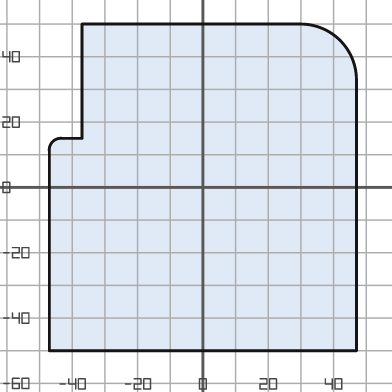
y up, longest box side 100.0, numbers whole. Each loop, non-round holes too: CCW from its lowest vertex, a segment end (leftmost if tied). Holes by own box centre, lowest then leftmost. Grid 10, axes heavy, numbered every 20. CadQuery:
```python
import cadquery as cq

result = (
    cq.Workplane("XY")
    .moveTo(-47.0, -50.0)
    .lineTo(47.0, -50.0)
    .lineTo(47.0, 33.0)
    .threePointArc((42.0, 45.0), (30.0, 50.0))
    .lineTo(-37.0, 50.0)
    .lineTo(-37.0, 15.0)
    .lineTo(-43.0, 15.0)
    .threePointArc((-46.0, 14.0), (-47.0, 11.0))
    .close()
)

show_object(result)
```